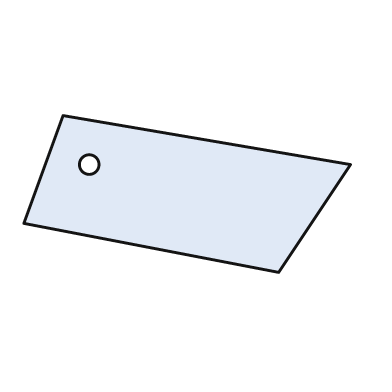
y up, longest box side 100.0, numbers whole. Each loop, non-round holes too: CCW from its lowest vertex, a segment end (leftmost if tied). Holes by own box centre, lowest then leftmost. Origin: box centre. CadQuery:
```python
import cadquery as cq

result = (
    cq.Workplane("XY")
    .moveTo(28.0, -24.0)
    .lineTo(50.0, 9.0)
    .lineTo(-38.0, 24.0)
    .lineTo(-50.0, -9.0)
    .close()
    .moveTo(-30.0, 9.0)
    .circle(3.0)
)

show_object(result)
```